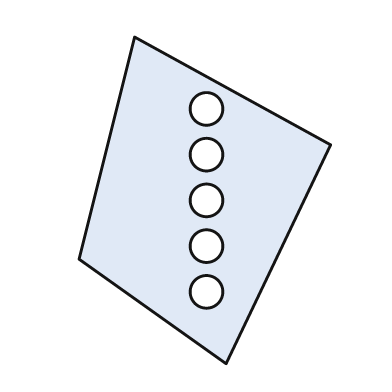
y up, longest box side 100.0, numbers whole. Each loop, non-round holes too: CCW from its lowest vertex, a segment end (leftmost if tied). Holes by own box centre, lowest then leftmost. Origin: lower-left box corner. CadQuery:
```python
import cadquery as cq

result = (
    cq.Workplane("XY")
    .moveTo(45.0, 0.0)
    .lineTo(77.0, 67.0)
    .lineTo(17.0, 100.0)
    .lineTo(0.0, 32.0)
    .close()
    .moveTo(39.0, 22.0)
    .circle(5.0)
    .moveTo(39.0, 36.0)
    .circle(5.0)
    .moveTo(39.0, 50.0)
    .circle(5.0)
    .moveTo(39.0, 64.0)
    .circle(5.0)
    .moveTo(39.0, 78.0)
    .circle(5.0)
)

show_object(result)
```